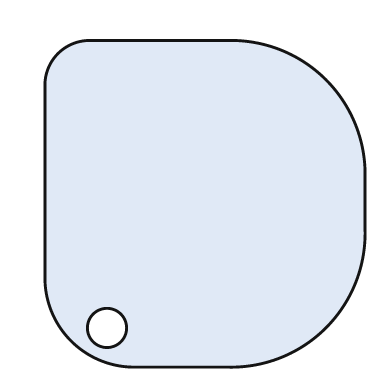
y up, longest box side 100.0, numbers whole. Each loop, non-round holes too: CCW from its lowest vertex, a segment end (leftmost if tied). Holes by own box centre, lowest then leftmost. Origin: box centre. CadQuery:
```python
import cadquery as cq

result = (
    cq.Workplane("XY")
    .moveTo(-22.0, -50.0)
    .lineTo(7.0, -50.0)
    .threePointArc((37.0, -38.0), (49.0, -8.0))
    .lineTo(49.0, 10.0)
    .threePointArc((37.0, 38.0), (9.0, 50.0))
    .lineTo(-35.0, 50.0)
    .threePointArc((-45.0, 46.0), (-49.0, 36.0))
    .lineTo(-49.0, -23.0)
    .threePointArc((-41.0, -42.0), (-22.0, -50.0))
    .close()
    .moveTo(-30.0, -38.0)
    .circle(6.0)
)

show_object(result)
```